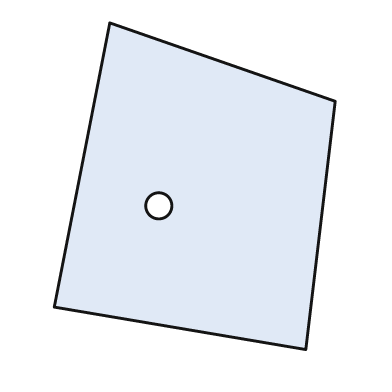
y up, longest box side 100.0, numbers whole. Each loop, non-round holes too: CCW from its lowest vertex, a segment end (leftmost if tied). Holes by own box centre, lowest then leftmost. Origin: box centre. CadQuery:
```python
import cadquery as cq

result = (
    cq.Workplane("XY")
    .moveTo(34.0, -50.0)
    .lineTo(43.0, 26.0)
    .lineTo(-26.0, 50.0)
    .lineTo(-43.0, -37.0)
    .close()
    .moveTo(-11.0, -6.0)
    .circle(4.0)
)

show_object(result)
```